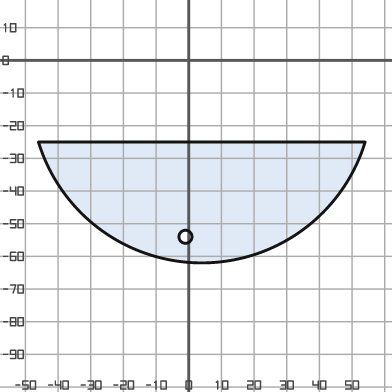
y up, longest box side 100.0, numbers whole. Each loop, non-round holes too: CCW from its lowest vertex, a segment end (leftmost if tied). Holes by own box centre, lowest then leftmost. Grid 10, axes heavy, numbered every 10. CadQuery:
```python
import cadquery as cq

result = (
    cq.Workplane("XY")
    .moveTo(-46.0, -25.0)
    .threePointArc((4.0, -62.0), (54.0, -25.0))
    .close()
    .moveTo(-1.0, -54.0)
    .circle(2.0)
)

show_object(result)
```